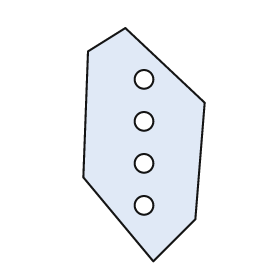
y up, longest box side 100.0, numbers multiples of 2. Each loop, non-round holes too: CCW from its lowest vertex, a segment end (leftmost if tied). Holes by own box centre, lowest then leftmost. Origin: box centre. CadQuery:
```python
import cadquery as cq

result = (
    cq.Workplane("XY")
    .moveTo(4.0, -50.0)
    .lineTo(22.0, -32.0)
    .lineTo(26.0, 18.0)
    .lineTo(-8.0, 50.0)
    .lineTo(-24.0, 40.0)
    .lineTo(-26.0, -14.0)
    .close()
    .moveTo(0.0, -26.0)
    .circle(4.0)
    .moveTo(0.0, -8.0)
    .circle(4.0)
    .moveTo(0.0, 10.0)
    .circle(4.0)
    .moveTo(0.0, 28.0)
    .circle(4.0)
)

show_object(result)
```